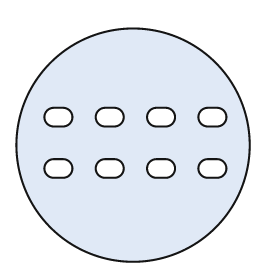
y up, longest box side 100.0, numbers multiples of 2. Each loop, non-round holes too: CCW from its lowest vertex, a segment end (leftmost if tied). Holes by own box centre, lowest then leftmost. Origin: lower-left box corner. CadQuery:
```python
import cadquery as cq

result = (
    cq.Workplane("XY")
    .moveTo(50.0, 50.0)
    .circle(50.0)
    .moveTo(16.0, 36.0)
    .lineTo(20.0, 36.0)
    .threePointArc((24.0, 40.0), (20.0, 44.0))
    .lineTo(16.0, 44.0)
    .threePointArc((12.0, 40.0), (16.0, 36.0))
    .close()
    .moveTo(38.0, 36.0)
    .lineTo(42.0, 36.0)
    .threePointArc((46.0, 40.0), (42.0, 44.0))
    .lineTo(38.0, 44.0)
    .threePointArc((34.0, 40.0), (38.0, 36.0))
    .close()
    .moveTo(60.0, 36.0)
    .lineTo(64.0, 36.0)
    .threePointArc((68.0, 40.0), (64.0, 44.0))
    .lineTo(60.0, 44.0)
    .threePointArc((56.0, 40.0), (60.0, 36.0))
    .close()
    .moveTo(82.0, 36.0)
    .lineTo(86.0, 36.0)
    .threePointArc((90.0, 40.0), (86.0, 44.0))
    .lineTo(82.0, 44.0)
    .threePointArc((78.0, 40.0), (82.0, 36.0))
    .close()
    .moveTo(16.0, 58.0)
    .lineTo(20.0, 58.0)
    .threePointArc((24.0, 62.0), (20.0, 66.0))
    .lineTo(16.0, 66.0)
    .threePointArc((12.0, 62.0), (16.0, 58.0))
    .close()
    .moveTo(38.0, 58.0)
    .lineTo(42.0, 58.0)
    .threePointArc((46.0, 62.0), (42.0, 66.0))
    .lineTo(38.0, 66.0)
    .threePointArc((34.0, 62.0), (38.0, 58.0))
    .close()
    .moveTo(60.0, 58.0)
    .lineTo(64.0, 58.0)
    .threePointArc((68.0, 62.0), (64.0, 66.0))
    .lineTo(60.0, 66.0)
    .threePointArc((56.0, 62.0), (60.0, 58.0))
    .close()
    .moveTo(82.0, 58.0)
    .lineTo(86.0, 58.0)
    .threePointArc((90.0, 62.0), (86.0, 66.0))
    .lineTo(82.0, 66.0)
    .threePointArc((78.0, 62.0), (82.0, 58.0))
    .close()
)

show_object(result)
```